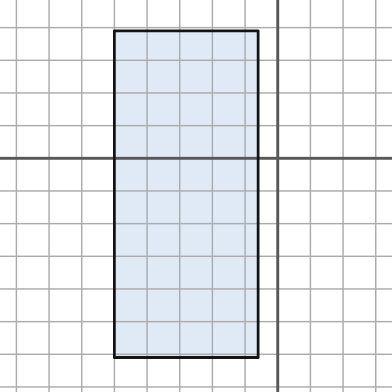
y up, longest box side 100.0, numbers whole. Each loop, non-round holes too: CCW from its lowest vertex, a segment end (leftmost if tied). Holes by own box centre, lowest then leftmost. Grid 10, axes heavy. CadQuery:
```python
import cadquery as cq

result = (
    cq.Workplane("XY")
    .moveTo(-50.0, -61.0)
    .lineTo(-6.0, -61.0)
    .lineTo(-6.0, 39.0)
    .lineTo(-50.0, 39.0)
    .close()
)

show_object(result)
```